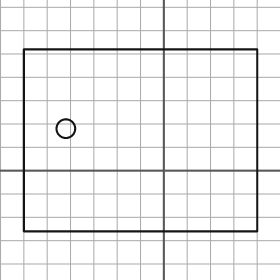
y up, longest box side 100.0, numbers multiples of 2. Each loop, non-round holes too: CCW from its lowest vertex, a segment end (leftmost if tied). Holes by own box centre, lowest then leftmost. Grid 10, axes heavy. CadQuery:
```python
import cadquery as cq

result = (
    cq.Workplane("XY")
    .moveTo(-60.0, -26.0)
    .lineTo(40.0, -26.0)
    .lineTo(40.0, 52.0)
    .lineTo(-60.0, 52.0)
    .close()
    .moveTo(-42.0, 18.0)
    .circle(4.0)
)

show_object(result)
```